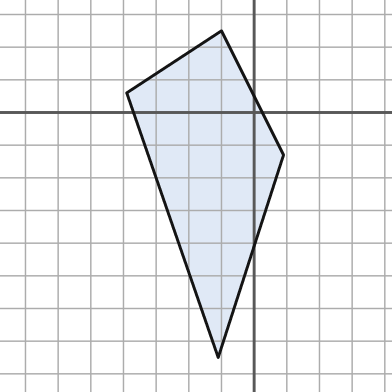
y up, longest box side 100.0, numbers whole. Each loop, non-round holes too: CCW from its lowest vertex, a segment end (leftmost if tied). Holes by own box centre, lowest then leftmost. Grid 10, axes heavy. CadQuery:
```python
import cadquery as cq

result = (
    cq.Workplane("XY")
    .moveTo(-11.0, -75.0)
    .lineTo(9.0, -13.0)
    .lineTo(-10.0, 25.0)
    .lineTo(-39.0, 6.0)
    .close()
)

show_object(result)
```